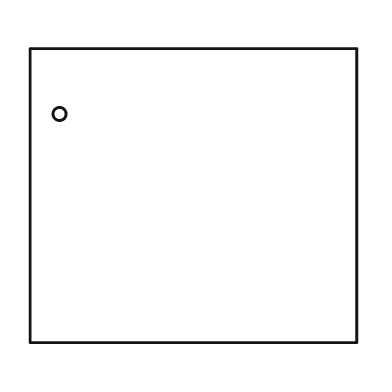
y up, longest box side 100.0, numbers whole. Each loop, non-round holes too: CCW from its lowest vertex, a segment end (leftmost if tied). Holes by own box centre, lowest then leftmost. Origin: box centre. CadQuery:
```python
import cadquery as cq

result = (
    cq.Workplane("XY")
    .moveTo(-50.0, -45.0)
    .lineTo(50.0, -45.0)
    .lineTo(50.0, 45.0)
    .lineTo(-50.0, 45.0)
    .close()
    .moveTo(-41.0, 25.0)
    .circle(2.0)
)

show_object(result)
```